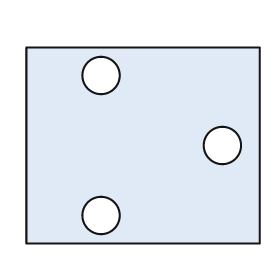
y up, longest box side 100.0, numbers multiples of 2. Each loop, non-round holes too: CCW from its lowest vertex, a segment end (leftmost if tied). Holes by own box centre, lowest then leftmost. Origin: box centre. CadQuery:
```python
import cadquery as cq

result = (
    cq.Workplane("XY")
    .moveTo(-50.0, -42.0)
    .lineTo(50.0, -42.0)
    .lineTo(50.0, 42.0)
    .lineTo(-50.0, 42.0)
    .close()
    .moveTo(-18.0, -30.0)
    .circle(8.0)
    .moveTo(34.0, 0.0)
    .circle(8.0)
    .moveTo(-18.0, 30.0)
    .circle(8.0)
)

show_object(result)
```